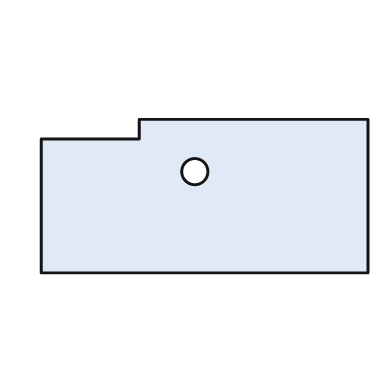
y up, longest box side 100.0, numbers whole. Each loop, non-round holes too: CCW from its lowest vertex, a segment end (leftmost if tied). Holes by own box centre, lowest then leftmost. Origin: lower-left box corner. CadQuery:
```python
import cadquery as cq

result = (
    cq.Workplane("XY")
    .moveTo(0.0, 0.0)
    .lineTo(100.0, 0.0)
    .lineTo(100.0, 47.0)
    .lineTo(30.0, 47.0)
    .lineTo(30.0, 41.0)
    .lineTo(0.0, 41.0)
    .close()
    .moveTo(47.0, 31.0)
    .circle(4.0)
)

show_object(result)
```